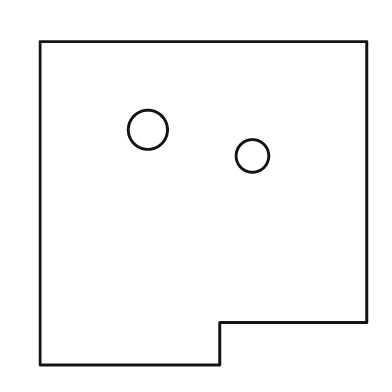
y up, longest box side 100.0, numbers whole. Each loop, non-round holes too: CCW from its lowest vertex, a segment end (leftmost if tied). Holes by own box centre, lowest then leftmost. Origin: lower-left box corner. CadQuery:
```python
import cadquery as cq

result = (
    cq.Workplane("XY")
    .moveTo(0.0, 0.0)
    .lineTo(55.0, 0.0)
    .lineTo(55.0, 13.0)
    .lineTo(100.0, 13.0)
    .lineTo(100.0, 99.0)
    .lineTo(0.0, 99.0)
    .close()
    .moveTo(65.0, 64.0)
    .circle(5.0)
    .moveTo(33.0, 72.0)
    .circle(6.0)
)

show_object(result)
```